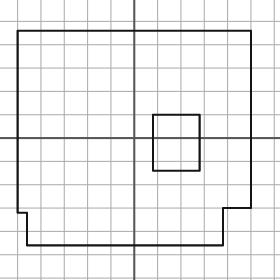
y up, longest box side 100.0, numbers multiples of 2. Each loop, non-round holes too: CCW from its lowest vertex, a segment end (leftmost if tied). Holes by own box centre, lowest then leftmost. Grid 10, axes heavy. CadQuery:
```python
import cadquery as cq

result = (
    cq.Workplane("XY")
    .moveTo(-46.0, -46.0)
    .lineTo(38.0, -46.0)
    .lineTo(38.0, -30.0)
    .lineTo(50.0, -30.0)
    .lineTo(50.0, 46.0)
    .lineTo(-50.0, 46.0)
    .lineTo(-50.0, -32.0)
    .lineTo(-46.0, -32.0)
    .close()
    .moveTo(8.0, -14.0)
    .lineTo(28.0, -14.0)
    .lineTo(28.0, 10.0)
    .lineTo(8.0, 10.0)
    .close()
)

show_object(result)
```